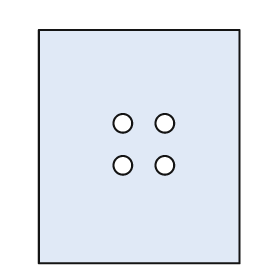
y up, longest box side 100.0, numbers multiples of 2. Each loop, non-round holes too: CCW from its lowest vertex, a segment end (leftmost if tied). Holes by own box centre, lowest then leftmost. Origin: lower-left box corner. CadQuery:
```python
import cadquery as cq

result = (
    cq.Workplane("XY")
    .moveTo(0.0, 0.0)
    .lineTo(86.0, 0.0)
    .lineTo(86.0, 100.0)
    .lineTo(0.0, 100.0)
    .close()
    .moveTo(36.0, 42.0)
    .circle(4.0)
    .moveTo(54.0, 42.0)
    .circle(4.0)
    .moveTo(36.0, 60.0)
    .circle(4.0)
    .moveTo(54.0, 60.0)
    .circle(4.0)
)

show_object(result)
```